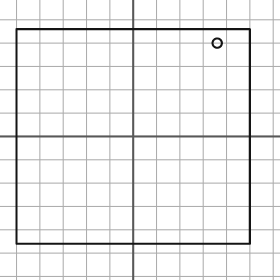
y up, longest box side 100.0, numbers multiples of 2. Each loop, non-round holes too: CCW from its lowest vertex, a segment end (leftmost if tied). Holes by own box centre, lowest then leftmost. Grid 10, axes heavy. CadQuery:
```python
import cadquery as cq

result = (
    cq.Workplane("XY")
    .moveTo(-50.0, -46.0)
    .lineTo(50.0, -46.0)
    .lineTo(50.0, 46.0)
    .lineTo(-50.0, 46.0)
    .close()
    .moveTo(36.0, 40.0)
    .circle(2.0)
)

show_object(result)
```